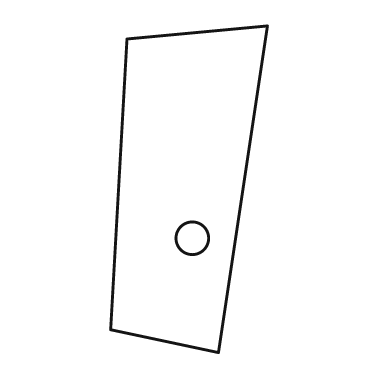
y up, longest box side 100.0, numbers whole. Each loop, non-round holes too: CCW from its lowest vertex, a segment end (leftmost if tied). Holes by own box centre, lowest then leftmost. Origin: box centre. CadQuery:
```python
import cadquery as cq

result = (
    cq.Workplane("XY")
    .moveTo(9.0, -50.0)
    .lineTo(24.0, 50.0)
    .lineTo(-19.0, 46.0)
    .lineTo(-24.0, -43.0)
    .close()
    .moveTo(1.0, -15.0)
    .circle(5.0)
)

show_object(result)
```